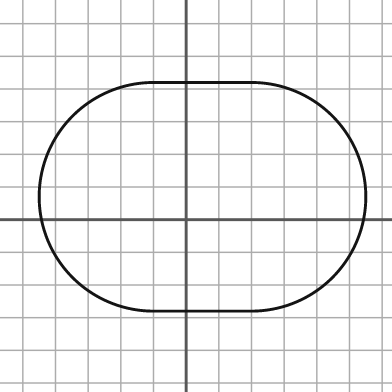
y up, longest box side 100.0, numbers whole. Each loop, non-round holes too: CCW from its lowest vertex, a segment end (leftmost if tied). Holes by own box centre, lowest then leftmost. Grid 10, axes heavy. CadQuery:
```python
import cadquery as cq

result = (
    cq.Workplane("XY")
    .moveTo(-10.0, -28.0)
    .lineTo(20.0, -28.0)
    .threePointArc((55.0, 7.0), (20.0, 42.0))
    .lineTo(-10.0, 42.0)
    .threePointArc((-45.0, 7.0), (-10.0, -28.0))
    .close()
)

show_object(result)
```